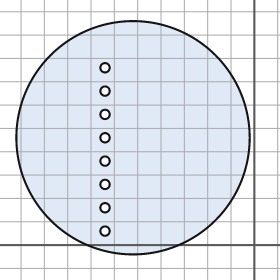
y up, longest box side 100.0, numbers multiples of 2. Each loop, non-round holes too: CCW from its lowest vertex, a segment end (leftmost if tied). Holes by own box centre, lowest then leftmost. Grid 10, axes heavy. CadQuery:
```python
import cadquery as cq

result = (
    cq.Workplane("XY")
    .moveTo(-52.0, 46.0)
    .circle(50.0)
    .moveTo(-64.0, 6.0)
    .circle(2.0)
    .moveTo(-64.0, 16.0)
    .circle(2.0)
    .moveTo(-64.0, 26.0)
    .circle(2.0)
    .moveTo(-64.0, 36.0)
    .circle(2.0)
    .moveTo(-64.0, 46.0)
    .circle(2.0)
    .moveTo(-64.0, 56.0)
    .circle(2.0)
    .moveTo(-64.0, 66.0)
    .circle(2.0)
    .moveTo(-64.0, 76.0)
    .circle(2.0)
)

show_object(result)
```